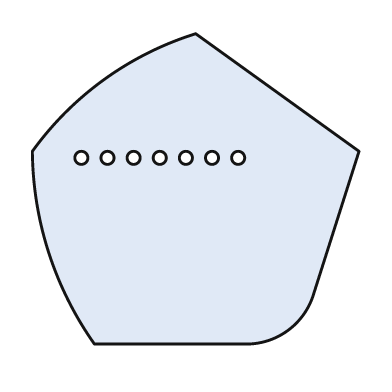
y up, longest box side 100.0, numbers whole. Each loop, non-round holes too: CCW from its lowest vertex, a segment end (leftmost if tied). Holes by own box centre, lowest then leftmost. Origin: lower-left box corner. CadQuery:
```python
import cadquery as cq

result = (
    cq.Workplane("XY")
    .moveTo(19.0, 0.0)
    .lineTo(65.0, 0.0)
    .threePointArc((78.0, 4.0), (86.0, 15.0))
    .lineTo(100.0, 59.0)
    .lineTo(50.0, 95.0)
    .threePointArc((22.0, 81.0), (0.0, 59.0))
    .threePointArc((5.0, 28.0), (19.0, 0.0))
    .close()
    .moveTo(15.0, 57.0)
    .circle(2.0)
    .moveTo(23.0, 57.0)
    .circle(2.0)
    .moveTo(31.0, 57.0)
    .circle(2.0)
    .moveTo(39.0, 57.0)
    .circle(2.0)
    .moveTo(47.0, 57.0)
    .circle(2.0)
    .moveTo(55.0, 57.0)
    .circle(2.0)
    .moveTo(63.0, 57.0)
    .circle(2.0)
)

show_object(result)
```